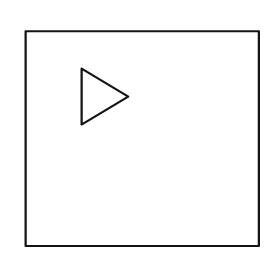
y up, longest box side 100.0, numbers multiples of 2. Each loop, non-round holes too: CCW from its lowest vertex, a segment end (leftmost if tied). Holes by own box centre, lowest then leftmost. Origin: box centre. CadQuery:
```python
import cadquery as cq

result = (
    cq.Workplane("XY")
    .moveTo(-50.0, -46.0)
    .lineTo(50.0, -46.0)
    .lineTo(50.0, 46.0)
    .lineTo(-50.0, 46.0)
    .close()
    .moveTo(-26.0, 6.0)
    .lineTo(-6.0, 18.0)
    .lineTo(-26.0, 30.0)
    .close()
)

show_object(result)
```